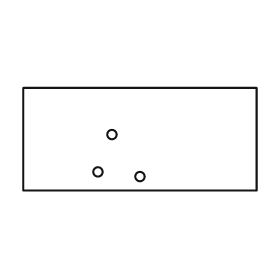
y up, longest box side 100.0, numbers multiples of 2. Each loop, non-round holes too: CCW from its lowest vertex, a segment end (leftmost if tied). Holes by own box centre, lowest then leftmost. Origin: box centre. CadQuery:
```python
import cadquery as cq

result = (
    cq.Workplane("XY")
    .moveTo(-50.0, -22.0)
    .lineTo(50.0, -22.0)
    .lineTo(50.0, 22.0)
    .lineTo(-50.0, 22.0)
    .close()
    .moveTo(0.0, -16.0)
    .circle(2.0)
    .moveTo(-18.0, -14.0)
    .circle(2.0)
    .moveTo(-12.0, 2.0)
    .circle(2.0)
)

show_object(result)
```